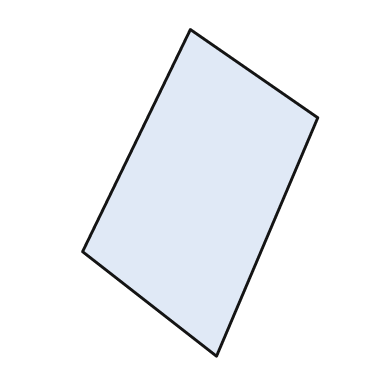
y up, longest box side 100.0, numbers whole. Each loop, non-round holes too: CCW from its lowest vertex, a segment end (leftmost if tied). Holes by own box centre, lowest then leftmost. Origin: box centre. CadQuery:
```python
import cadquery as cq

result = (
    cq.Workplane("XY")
    .moveTo(5.0, -50.0)
    .lineTo(36.0, 23.0)
    .lineTo(-3.0, 50.0)
    .lineTo(-36.0, -18.0)
    .close()
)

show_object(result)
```